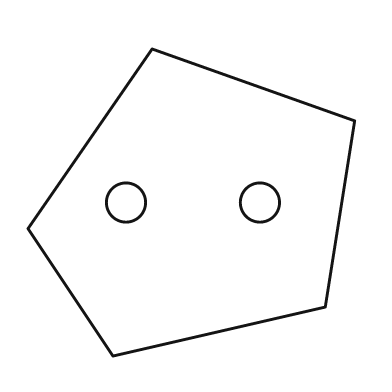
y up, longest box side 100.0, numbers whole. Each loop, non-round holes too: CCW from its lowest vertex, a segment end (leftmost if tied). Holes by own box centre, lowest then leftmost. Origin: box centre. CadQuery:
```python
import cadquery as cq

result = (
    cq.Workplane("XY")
    .moveTo(-24.0, -47.0)
    .lineTo(41.0, -32.0)
    .lineTo(50.0, 25.0)
    .lineTo(-12.0, 47.0)
    .lineTo(-50.0, -8.0)
    .close()
    .moveTo(-20.0, 0.0)
    .circle(6.0)
    .moveTo(21.0, 0.0)
    .circle(6.0)
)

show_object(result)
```